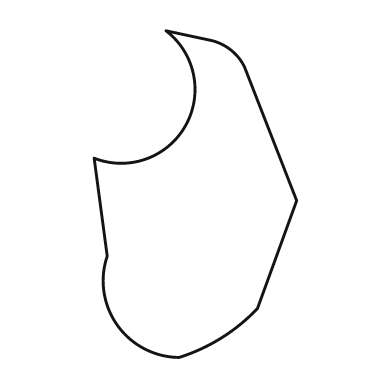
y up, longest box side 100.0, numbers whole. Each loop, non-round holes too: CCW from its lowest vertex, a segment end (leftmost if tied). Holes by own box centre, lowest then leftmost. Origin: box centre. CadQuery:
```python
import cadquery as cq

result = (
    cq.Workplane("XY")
    .moveTo(-5.0, -50.0)
    .threePointArc((8.0, -44.0), (19.0, -35.0))
    .lineTo(31.0, -2.0)
    .lineTo(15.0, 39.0)
    .threePointArc((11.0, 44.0), (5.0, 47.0))
    .lineTo(-9.0, 50.0)
    .threePointArc((-3.0, 21.0), (-31.0, 11.0))
    .lineTo(-27.0, -19.0)
    .threePointArc((-24.0, -40.0), (-5.0, -50.0))
    .close()
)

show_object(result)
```